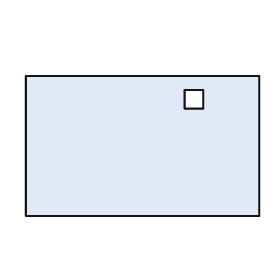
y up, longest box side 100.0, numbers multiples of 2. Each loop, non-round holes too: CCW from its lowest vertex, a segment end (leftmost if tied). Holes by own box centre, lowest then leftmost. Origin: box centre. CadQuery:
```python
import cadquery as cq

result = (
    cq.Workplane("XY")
    .moveTo(-50.0, -30.0)
    .lineTo(50.0, -30.0)
    .lineTo(50.0, 30.0)
    .lineTo(-50.0, 30.0)
    .close()
    .moveTo(18.0, 16.0)
    .lineTo(26.0, 16.0)
    .lineTo(26.0, 24.0)
    .lineTo(18.0, 24.0)
    .close()
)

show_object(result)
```